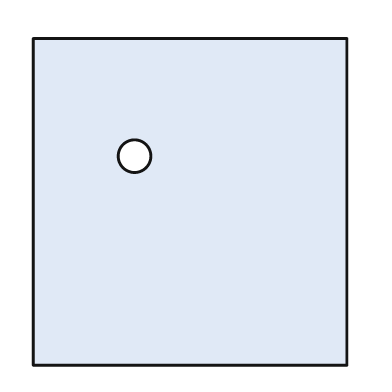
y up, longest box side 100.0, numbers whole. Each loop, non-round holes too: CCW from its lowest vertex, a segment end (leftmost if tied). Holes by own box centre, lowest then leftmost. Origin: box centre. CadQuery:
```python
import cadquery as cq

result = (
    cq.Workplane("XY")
    .moveTo(-48.0, -50.0)
    .lineTo(48.0, -50.0)
    .lineTo(48.0, 50.0)
    .lineTo(-48.0, 50.0)
    .close()
    .moveTo(-17.0, 14.0)
    .circle(5.0)
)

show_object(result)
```